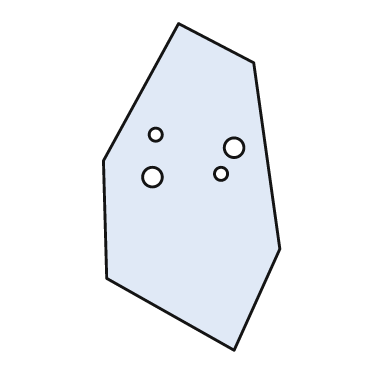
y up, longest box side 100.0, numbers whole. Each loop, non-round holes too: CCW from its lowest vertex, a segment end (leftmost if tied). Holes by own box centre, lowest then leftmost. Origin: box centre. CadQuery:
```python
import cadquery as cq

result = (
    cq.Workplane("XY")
    .moveTo(13.0, -50.0)
    .lineTo(27.0, -19.0)
    .lineTo(19.0, 38.0)
    .lineTo(-4.0, 50.0)
    .lineTo(-27.0, 8.0)
    .lineTo(-26.0, -28.0)
    .close()
    .moveTo(-12.0, 3.0)
    .circle(3.0)
    .moveTo(9.0, 4.0)
    .circle(2.0)
    .moveTo(13.0, 12.0)
    .circle(3.0)
    .moveTo(-11.0, 16.0)
    .circle(2.0)
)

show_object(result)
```